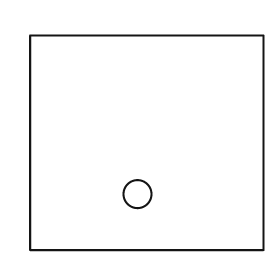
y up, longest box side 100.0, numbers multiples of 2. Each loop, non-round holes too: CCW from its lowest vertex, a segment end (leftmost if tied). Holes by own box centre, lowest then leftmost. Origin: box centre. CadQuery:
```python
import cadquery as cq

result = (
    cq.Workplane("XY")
    .moveTo(-50.0, -46.0)
    .lineTo(50.0, -46.0)
    .lineTo(50.0, 46.0)
    .lineTo(-50.0, 46.0)
    .close()
    .moveTo(-4.0, -22.0)
    .circle(6.0)
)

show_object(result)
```